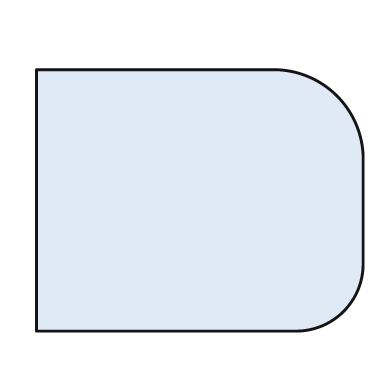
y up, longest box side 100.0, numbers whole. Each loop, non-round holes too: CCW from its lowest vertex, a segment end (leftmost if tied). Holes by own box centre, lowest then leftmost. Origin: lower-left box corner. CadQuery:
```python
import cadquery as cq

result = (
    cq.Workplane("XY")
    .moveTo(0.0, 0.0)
    .lineTo(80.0, 0.0)
    .threePointArc((94.0, 6.0), (100.0, 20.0))
    .lineTo(100.0, 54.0)
    .threePointArc((92.0, 72.0), (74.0, 80.0))
    .lineTo(0.0, 80.0)
    .close()
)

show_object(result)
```